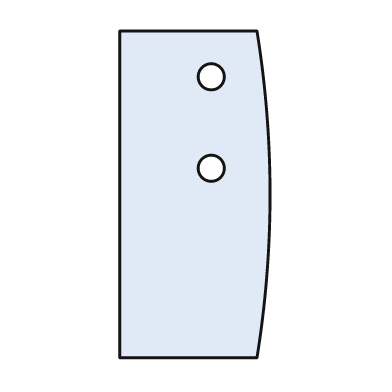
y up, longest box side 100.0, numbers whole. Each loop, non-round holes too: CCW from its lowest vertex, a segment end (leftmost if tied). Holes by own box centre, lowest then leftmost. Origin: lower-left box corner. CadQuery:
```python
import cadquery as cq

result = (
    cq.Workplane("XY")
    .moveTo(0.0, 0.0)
    .lineTo(42.0, 0.0)
    .threePointArc((46.0, 50.0), (42.0, 100.0))
    .lineTo(0.0, 100.0)
    .close()
    .moveTo(28.0, 58.0)
    .circle(4.0)
    .moveTo(28.0, 86.0)
    .circle(4.0)
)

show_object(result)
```